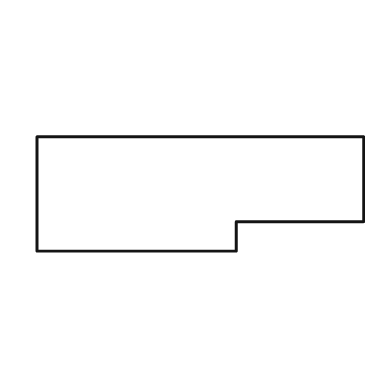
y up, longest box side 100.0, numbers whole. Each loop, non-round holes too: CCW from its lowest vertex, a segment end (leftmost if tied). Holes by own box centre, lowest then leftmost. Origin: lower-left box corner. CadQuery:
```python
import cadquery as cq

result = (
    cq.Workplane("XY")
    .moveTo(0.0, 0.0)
    .lineTo(61.0, 0.0)
    .lineTo(61.0, 9.0)
    .lineTo(100.0, 9.0)
    .lineTo(100.0, 35.0)
    .lineTo(0.0, 35.0)
    .close()
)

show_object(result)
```